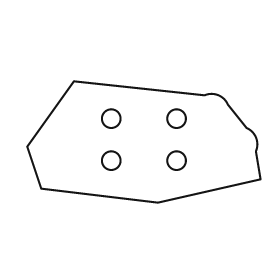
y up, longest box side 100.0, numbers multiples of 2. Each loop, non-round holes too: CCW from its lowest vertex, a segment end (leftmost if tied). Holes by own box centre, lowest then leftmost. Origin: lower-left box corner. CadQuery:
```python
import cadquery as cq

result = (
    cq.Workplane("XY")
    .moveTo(56.0, 0.0)
    .lineTo(100.0, 10.0)
    .lineTo(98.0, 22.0)
    .threePointArc((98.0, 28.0), (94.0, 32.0))
    .lineTo(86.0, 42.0)
    .threePointArc((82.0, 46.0), (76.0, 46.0))
    .lineTo(20.0, 52.0)
    .lineTo(0.0, 24.0)
    .lineTo(6.0, 6.0)
    .close()
    .moveTo(36.0, 18.0)
    .circle(4.0)
    .moveTo(64.0, 18.0)
    .circle(4.0)
    .moveTo(36.0, 36.0)
    .circle(4.0)
    .moveTo(64.0, 36.0)
    .circle(4.0)
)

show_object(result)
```